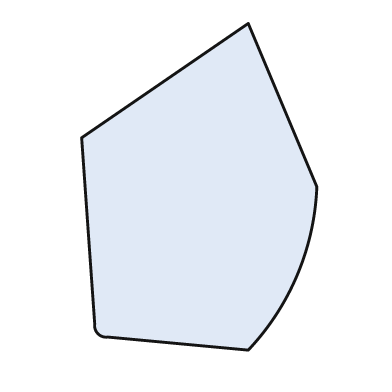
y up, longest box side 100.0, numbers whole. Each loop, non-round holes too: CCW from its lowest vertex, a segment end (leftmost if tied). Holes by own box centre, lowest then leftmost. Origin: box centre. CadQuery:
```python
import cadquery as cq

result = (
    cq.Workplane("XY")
    .moveTo(15.0, -50.0)
    .threePointArc((30.0, -27.0), (36.0, 0.0))
    .lineTo(15.0, 50.0)
    .lineTo(-36.0, 15.0)
    .lineTo(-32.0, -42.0)
    .threePointArc((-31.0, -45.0), (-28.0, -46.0))
    .close()
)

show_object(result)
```